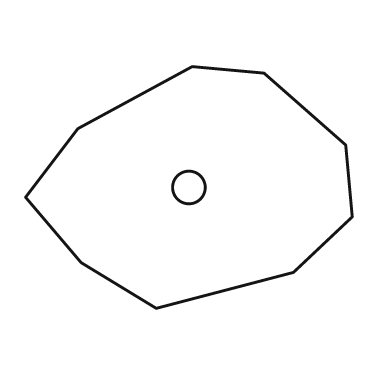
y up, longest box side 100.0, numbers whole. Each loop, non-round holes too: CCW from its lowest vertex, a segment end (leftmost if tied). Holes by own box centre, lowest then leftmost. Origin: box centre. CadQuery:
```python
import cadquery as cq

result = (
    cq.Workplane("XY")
    .moveTo(-10.0, -37.0)
    .lineTo(32.0, -26.0)
    .lineTo(50.0, -9.0)
    .lineTo(48.0, 13.0)
    .lineTo(23.0, 35.0)
    .lineTo(1.0, 37.0)
    .lineTo(-34.0, 18.0)
    .lineTo(-50.0, -3.0)
    .lineTo(-33.0, -23.0)
    .close()
    .moveTo(0.0, 0.0)
    .circle(5.0)
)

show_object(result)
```